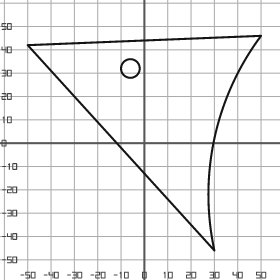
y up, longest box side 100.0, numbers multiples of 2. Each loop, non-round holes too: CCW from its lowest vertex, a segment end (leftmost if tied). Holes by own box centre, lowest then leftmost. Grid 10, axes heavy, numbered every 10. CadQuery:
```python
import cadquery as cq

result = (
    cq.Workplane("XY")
    .moveTo(30.0, -46.0)
    .threePointArc((30.0, 2.0), (50.0, 46.0))
    .lineTo(-50.0, 42.0)
    .close()
    .moveTo(-6.0, 32.0)
    .circle(4.0)
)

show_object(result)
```